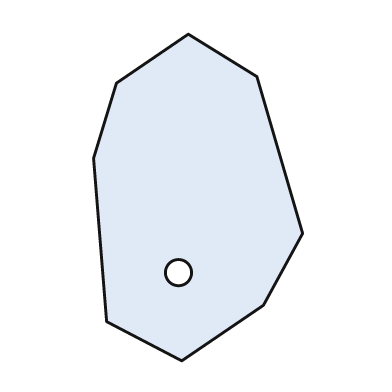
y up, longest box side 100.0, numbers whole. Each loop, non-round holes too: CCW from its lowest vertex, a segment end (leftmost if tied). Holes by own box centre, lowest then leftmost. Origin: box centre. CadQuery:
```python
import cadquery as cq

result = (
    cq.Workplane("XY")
    .moveTo(-5.0, -50.0)
    .lineTo(20.0, -33.0)
    .lineTo(32.0, -11.0)
    .lineTo(18.0, 37.0)
    .lineTo(-3.0, 50.0)
    .lineTo(-25.0, 35.0)
    .lineTo(-32.0, 12.0)
    .lineTo(-28.0, -38.0)
    .close()
    .moveTo(-6.0, -23.0)
    .circle(4.0)
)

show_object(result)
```